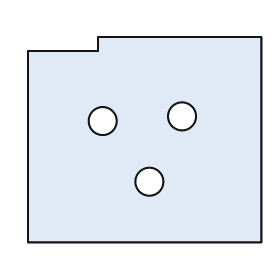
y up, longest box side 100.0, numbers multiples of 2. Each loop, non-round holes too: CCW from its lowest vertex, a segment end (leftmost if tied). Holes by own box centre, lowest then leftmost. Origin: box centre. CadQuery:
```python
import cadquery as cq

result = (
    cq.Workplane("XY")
    .moveTo(-50.0, -44.0)
    .lineTo(50.0, -44.0)
    .lineTo(50.0, 44.0)
    .lineTo(-20.0, 44.0)
    .lineTo(-20.0, 38.0)
    .lineTo(-50.0, 38.0)
    .close()
    .moveTo(2.0, -18.0)
    .circle(6.0)
    .moveTo(-18.0, 8.0)
    .circle(6.0)
    .moveTo(16.0, 10.0)
    .circle(6.0)
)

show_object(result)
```